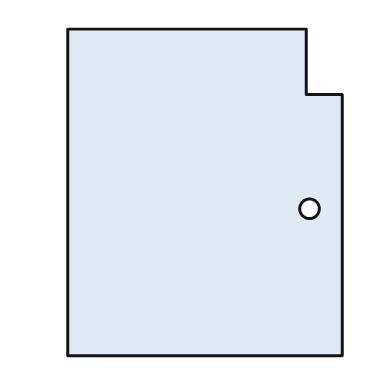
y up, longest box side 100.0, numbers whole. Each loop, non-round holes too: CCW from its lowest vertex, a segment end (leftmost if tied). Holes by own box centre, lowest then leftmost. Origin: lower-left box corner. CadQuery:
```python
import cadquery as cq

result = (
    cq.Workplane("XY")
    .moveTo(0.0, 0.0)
    .lineTo(84.0, 0.0)
    .lineTo(84.0, 80.0)
    .lineTo(73.0, 80.0)
    .lineTo(73.0, 100.0)
    .lineTo(0.0, 100.0)
    .close()
    .moveTo(74.0, 45.0)
    .circle(3.0)
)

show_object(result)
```